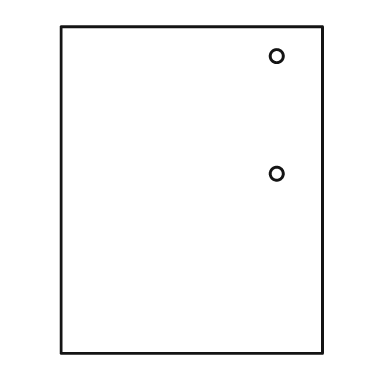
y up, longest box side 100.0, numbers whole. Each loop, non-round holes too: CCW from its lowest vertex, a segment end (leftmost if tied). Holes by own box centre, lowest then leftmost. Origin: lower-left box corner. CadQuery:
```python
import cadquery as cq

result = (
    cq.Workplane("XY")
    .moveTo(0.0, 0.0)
    .lineTo(80.0, 0.0)
    .lineTo(80.0, 100.0)
    .lineTo(0.0, 100.0)
    .close()
    .moveTo(66.0, 55.0)
    .circle(2.0)
    .moveTo(66.0, 91.0)
    .circle(2.0)
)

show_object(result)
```